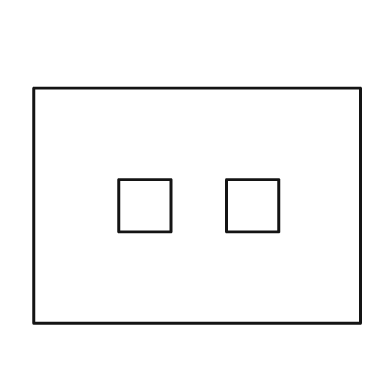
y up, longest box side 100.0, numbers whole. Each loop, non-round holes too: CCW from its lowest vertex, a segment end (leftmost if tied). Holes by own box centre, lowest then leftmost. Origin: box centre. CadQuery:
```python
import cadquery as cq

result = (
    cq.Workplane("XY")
    .moveTo(-50.0, -36.0)
    .lineTo(50.0, -36.0)
    .lineTo(50.0, 36.0)
    .lineTo(-50.0, 36.0)
    .close()
    .moveTo(-24.0, -8.0)
    .lineTo(-8.0, -8.0)
    .lineTo(-8.0, 8.0)
    .lineTo(-24.0, 8.0)
    .close()
    .moveTo(9.0, -8.0)
    .lineTo(25.0, -8.0)
    .lineTo(25.0, 8.0)
    .lineTo(9.0, 8.0)
    .close()
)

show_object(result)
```